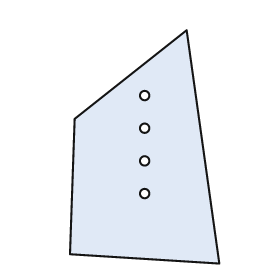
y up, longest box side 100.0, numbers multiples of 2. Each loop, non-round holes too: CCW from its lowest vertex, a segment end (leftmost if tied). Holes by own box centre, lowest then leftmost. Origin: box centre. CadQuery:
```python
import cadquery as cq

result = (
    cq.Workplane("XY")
    .moveTo(32.0, -50.0)
    .lineTo(18.0, 50.0)
    .lineTo(-30.0, 12.0)
    .lineTo(-32.0, -46.0)
    .close()
    .moveTo(0.0, -20.0)
    .circle(2.0)
    .moveTo(0.0, -6.0)
    .circle(2.0)
    .moveTo(0.0, 8.0)
    .circle(2.0)
    .moveTo(0.0, 22.0)
    .circle(2.0)
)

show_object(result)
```